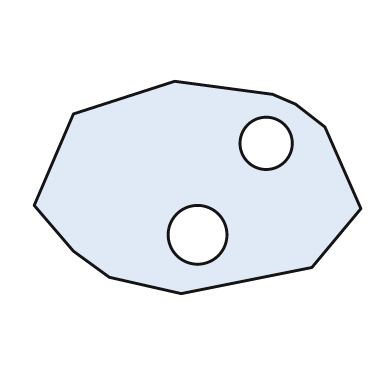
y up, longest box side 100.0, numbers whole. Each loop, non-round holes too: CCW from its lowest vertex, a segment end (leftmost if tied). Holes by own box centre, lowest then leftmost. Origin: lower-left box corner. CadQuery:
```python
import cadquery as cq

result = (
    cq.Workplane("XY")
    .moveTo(45.0, 0.0)
    .lineTo(85.0, 8.0)
    .lineTo(100.0, 26.0)
    .lineTo(89.0, 51.0)
    .lineTo(80.0, 58.0)
    .lineTo(73.0, 61.0)
    .lineTo(43.0, 65.0)
    .lineTo(12.0, 55.0)
    .lineTo(0.0, 27.0)
    .lineTo(12.0, 13.0)
    .lineTo(23.0, 5.0)
    .close()
    .moveTo(50.0, 18.0)
    .circle(9.0)
    .moveTo(71.0, 46.0)
    .circle(8.0)
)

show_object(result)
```